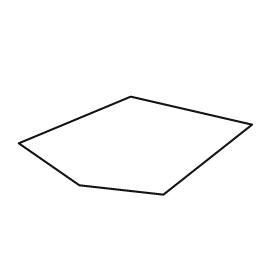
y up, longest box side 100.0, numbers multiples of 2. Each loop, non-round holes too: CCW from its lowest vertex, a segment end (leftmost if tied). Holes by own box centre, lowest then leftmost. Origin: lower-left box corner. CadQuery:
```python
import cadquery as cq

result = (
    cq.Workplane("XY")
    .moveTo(62.0, 0.0)
    .lineTo(100.0, 30.0)
    .lineTo(48.0, 42.0)
    .lineTo(0.0, 22.0)
    .lineTo(26.0, 4.0)
    .close()
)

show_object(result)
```